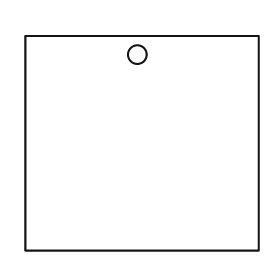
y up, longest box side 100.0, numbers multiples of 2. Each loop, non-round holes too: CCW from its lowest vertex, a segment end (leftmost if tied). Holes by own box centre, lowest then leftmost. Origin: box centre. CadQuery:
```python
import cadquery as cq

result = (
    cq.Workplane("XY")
    .moveTo(-50.0, -46.0)
    .lineTo(50.0, -46.0)
    .lineTo(50.0, 46.0)
    .lineTo(-50.0, 46.0)
    .close()
    .moveTo(-2.0, 38.0)
    .circle(4.0)
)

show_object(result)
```